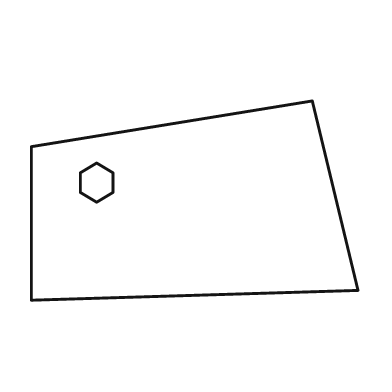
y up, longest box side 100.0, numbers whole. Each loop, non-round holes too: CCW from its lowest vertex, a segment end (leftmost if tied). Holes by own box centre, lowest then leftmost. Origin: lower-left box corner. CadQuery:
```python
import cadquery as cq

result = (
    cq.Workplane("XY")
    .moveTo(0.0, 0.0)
    .lineTo(100.0, 3.0)
    .lineTo(86.0, 61.0)
    .lineTo(0.0, 47.0)
    .close()
    .moveTo(20.0, 30.0)
    .lineTo(25.0, 33.0)
    .lineTo(25.0, 39.0)
    .lineTo(20.0, 42.0)
    .lineTo(15.0, 39.0)
    .lineTo(15.0, 33.0)
    .close()
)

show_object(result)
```